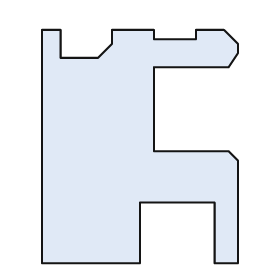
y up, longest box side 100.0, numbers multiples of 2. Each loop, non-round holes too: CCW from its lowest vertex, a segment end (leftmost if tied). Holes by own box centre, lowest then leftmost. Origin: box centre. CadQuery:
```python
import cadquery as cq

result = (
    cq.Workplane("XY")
    .moveTo(-42.0, -50.0)
    .lineTo(0.0, -50.0)
    .lineTo(0.0, -24.0)
    .lineTo(32.0, -24.0)
    .lineTo(32.0, -50.0)
    .lineTo(42.0, -50.0)
    .lineTo(42.0, -6.0)
    .lineTo(38.0, -2.0)
    .lineTo(6.0, -2.0)
    .lineTo(6.0, 34.0)
    .lineTo(38.0, 34.0)
    .lineTo(42.0, 40.0)
    .lineTo(42.0, 44.0)
    .lineTo(36.0, 50.0)
    .lineTo(24.0, 50.0)
    .lineTo(24.0, 46.0)
    .lineTo(6.0, 46.0)
    .lineTo(6.0, 50.0)
    .lineTo(-12.0, 50.0)
    .lineTo(-12.0, 44.0)
    .lineTo(-18.0, 38.0)
    .lineTo(-34.0, 38.0)
    .lineTo(-34.0, 50.0)
    .lineTo(-42.0, 50.0)
    .close()
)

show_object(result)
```